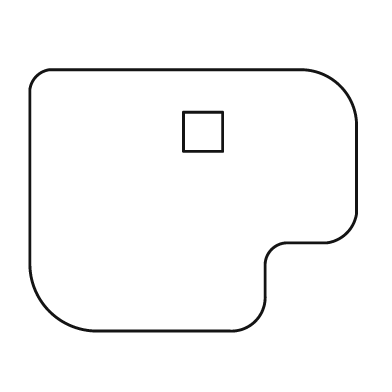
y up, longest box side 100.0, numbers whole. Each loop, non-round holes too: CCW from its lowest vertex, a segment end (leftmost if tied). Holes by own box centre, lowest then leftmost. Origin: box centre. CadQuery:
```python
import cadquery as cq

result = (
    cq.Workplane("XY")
    .moveTo(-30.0, -40.0)
    .lineTo(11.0, -40.0)
    .threePointArc((19.0, -37.0), (22.0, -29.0))
    .lineTo(22.0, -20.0)
    .threePointArc((24.0, -15.0), (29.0, -13.0))
    .lineTo(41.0, -13.0)
    .threePointArc((47.0, -10.0), (50.0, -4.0))
    .lineTo(50.0, 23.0)
    .threePointArc((45.0, 35.0), (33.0, 40.0))
    .lineTo(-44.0, 40.0)
    .threePointArc((-48.0, 38.0), (-50.0, 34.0))
    .lineTo(-50.0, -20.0)
    .threePointArc((-44.0, -34.0), (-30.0, -40.0))
    .close()
    .moveTo(-3.0, 15.0)
    .lineTo(9.0, 15.0)
    .lineTo(9.0, 27.0)
    .lineTo(-3.0, 27.0)
    .close()
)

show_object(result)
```